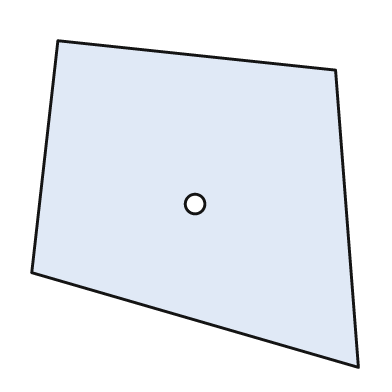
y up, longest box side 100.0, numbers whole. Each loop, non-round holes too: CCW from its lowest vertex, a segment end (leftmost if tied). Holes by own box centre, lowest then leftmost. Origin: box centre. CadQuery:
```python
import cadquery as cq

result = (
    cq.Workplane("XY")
    .moveTo(50.0, -50.0)
    .lineTo(43.0, 41.0)
    .lineTo(-42.0, 50.0)
    .lineTo(-50.0, -21.0)
    .close()
    .moveTo(0.0, 0.0)
    .circle(3.0)
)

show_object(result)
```